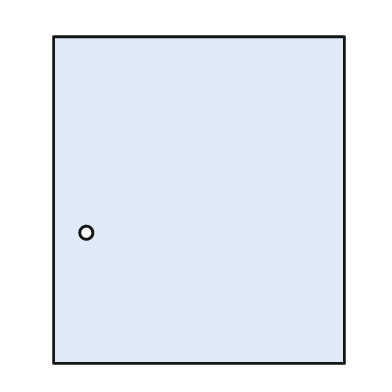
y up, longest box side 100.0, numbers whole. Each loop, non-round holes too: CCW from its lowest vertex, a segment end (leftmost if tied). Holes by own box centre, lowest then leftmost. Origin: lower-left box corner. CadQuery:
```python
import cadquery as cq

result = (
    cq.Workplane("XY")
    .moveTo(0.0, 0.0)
    .lineTo(89.0, 0.0)
    .lineTo(89.0, 100.0)
    .lineTo(0.0, 100.0)
    .close()
    .moveTo(10.0, 40.0)
    .circle(2.0)
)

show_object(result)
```